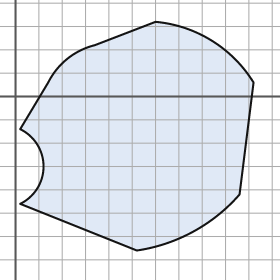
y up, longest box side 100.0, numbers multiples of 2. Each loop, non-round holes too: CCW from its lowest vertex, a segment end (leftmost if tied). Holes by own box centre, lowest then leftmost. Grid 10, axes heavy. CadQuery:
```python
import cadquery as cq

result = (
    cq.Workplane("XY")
    .moveTo(52.0, -66.0)
    .threePointArc((76.0, -58.0), (96.0, -42.0))
    .lineTo(102.0, 6.0)
    .threePointArc((84.0, 24.0), (60.0, 32.0))
    .lineTo(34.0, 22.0)
    .threePointArc((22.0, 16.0), (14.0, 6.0))
    .lineTo(2.0, -14.0)
    .threePointArc((12.0, -30.0), (2.0, -46.0))
    .close()
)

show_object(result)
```